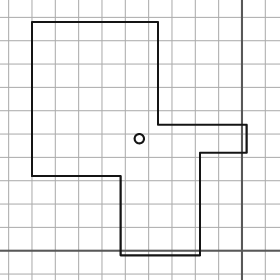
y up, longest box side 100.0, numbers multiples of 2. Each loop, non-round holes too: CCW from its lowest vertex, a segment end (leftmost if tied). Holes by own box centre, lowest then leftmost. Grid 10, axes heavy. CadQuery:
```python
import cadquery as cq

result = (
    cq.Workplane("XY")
    .moveTo(-52.0, -2.0)
    .lineTo(-18.0, -2.0)
    .lineTo(-18.0, 42.0)
    .lineTo(2.0, 42.0)
    .lineTo(2.0, 54.0)
    .lineTo(-36.0, 54.0)
    .lineTo(-36.0, 98.0)
    .lineTo(-90.0, 98.0)
    .lineTo(-90.0, 32.0)
    .lineTo(-52.0, 32.0)
    .close()
    .moveTo(-44.0, 48.0)
    .circle(2.0)
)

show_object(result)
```